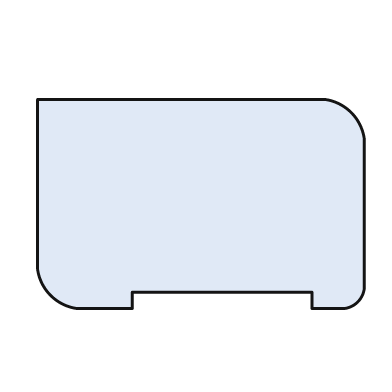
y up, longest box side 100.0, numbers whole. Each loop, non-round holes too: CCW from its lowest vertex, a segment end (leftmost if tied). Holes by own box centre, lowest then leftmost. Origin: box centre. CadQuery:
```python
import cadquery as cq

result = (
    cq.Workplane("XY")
    .moveTo(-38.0, -32.0)
    .lineTo(-21.0, -32.0)
    .lineTo(-21.0, -27.0)
    .lineTo(34.0, -27.0)
    .lineTo(34.0, -32.0)
    .lineTo(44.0, -32.0)
    .threePointArc((48.0, -30.0), (50.0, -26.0))
    .lineTo(50.0, 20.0)
    .threePointArc((46.0, 28.0), (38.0, 32.0))
    .lineTo(-50.0, 32.0)
    .lineTo(-50.0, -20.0)
    .threePointArc((-46.0, -28.0), (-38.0, -32.0))
    .close()
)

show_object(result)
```